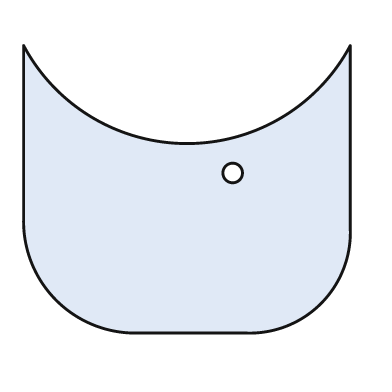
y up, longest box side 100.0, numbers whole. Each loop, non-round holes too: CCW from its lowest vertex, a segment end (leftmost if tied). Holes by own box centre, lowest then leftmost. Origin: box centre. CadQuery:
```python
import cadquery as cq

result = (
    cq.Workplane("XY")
    .moveTo(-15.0, -44.0)
    .lineTo(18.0, -44.0)
    .threePointArc((41.0, -35.0), (50.0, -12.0))
    .lineTo(50.0, 44.0)
    .threePointArc((0.0, 14.0), (-50.0, 44.0))
    .lineTo(-50.0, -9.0)
    .threePointArc((-40.0, -34.0), (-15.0, -44.0))
    .close()
    .moveTo(14.0, 5.0)
    .circle(3.0)
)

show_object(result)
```